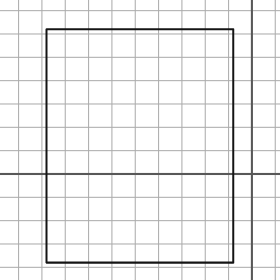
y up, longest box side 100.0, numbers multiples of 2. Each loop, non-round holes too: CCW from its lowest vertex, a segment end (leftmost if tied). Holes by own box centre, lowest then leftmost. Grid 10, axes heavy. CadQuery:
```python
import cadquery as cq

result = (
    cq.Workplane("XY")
    .moveTo(-88.0, -38.0)
    .lineTo(-8.0, -38.0)
    .lineTo(-8.0, 62.0)
    .lineTo(-88.0, 62.0)
    .close()
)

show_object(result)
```